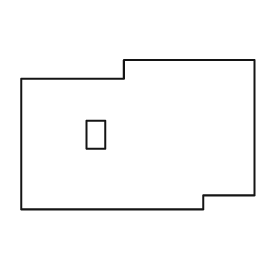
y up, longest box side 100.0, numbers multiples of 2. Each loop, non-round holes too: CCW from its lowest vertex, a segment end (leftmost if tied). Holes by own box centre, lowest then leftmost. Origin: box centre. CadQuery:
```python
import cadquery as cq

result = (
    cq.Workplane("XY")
    .moveTo(-50.0, -32.0)
    .lineTo(28.0, -32.0)
    .lineTo(28.0, -26.0)
    .lineTo(50.0, -26.0)
    .lineTo(50.0, 32.0)
    .lineTo(-6.0, 32.0)
    .lineTo(-6.0, 24.0)
    .lineTo(-50.0, 24.0)
    .close()
    .moveTo(-22.0, -6.0)
    .lineTo(-14.0, -6.0)
    .lineTo(-14.0, 6.0)
    .lineTo(-22.0, 6.0)
    .close()
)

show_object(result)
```